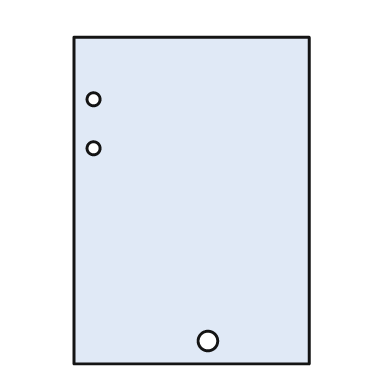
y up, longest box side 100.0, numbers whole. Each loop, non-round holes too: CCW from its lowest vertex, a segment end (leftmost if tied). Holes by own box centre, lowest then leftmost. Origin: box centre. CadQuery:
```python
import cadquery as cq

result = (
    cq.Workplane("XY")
    .moveTo(-36.0, -50.0)
    .lineTo(36.0, -50.0)
    .lineTo(36.0, 50.0)
    .lineTo(-36.0, 50.0)
    .close()
    .moveTo(5.0, -43.0)
    .circle(3.0)
    .moveTo(-30.0, 16.0)
    .circle(2.0)
    .moveTo(-30.0, 31.0)
    .circle(2.0)
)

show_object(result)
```